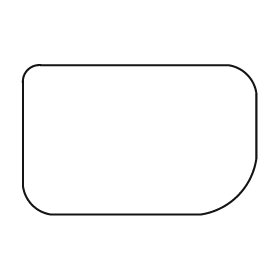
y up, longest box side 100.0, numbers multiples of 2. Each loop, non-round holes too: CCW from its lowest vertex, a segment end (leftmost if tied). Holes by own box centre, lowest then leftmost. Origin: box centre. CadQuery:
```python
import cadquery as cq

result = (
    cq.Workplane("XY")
    .moveTo(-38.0, -32.0)
    .lineTo(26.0, -32.0)
    .threePointArc((42.0, -24.0), (50.0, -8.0))
    .lineTo(50.0, 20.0)
    .threePointArc((46.0, 28.0), (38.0, 32.0))
    .lineTo(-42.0, 32.0)
    .threePointArc((-48.0, 30.0), (-50.0, 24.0))
    .lineTo(-50.0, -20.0)
    .threePointArc((-46.0, -28.0), (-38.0, -32.0))
    .close()
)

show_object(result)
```